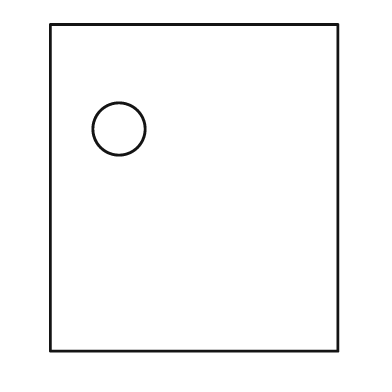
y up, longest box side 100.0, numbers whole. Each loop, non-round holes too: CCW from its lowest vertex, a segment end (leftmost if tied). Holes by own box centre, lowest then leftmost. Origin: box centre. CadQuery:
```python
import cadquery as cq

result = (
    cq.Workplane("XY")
    .moveTo(-44.0, -50.0)
    .lineTo(44.0, -50.0)
    .lineTo(44.0, 50.0)
    .lineTo(-44.0, 50.0)
    .close()
    .moveTo(-23.0, 18.0)
    .circle(8.0)
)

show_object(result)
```